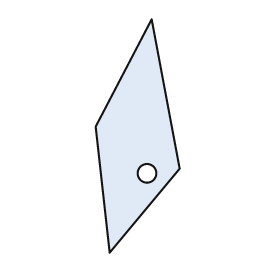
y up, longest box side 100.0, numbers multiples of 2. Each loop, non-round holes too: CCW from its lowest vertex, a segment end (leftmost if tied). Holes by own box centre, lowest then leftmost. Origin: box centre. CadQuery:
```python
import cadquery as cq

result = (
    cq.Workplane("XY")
    .moveTo(-12.0, -50.0)
    .lineTo(18.0, -14.0)
    .lineTo(6.0, 50.0)
    .lineTo(-18.0, 4.0)
    .close()
    .moveTo(4.0, -16.0)
    .circle(4.0)
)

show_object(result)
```